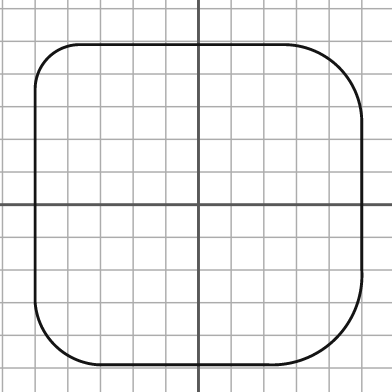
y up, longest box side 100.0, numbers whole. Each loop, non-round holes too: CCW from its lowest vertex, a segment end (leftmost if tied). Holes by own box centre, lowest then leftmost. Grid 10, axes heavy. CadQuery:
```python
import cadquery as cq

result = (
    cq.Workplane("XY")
    .moveTo(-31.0, -49.0)
    .lineTo(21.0, -49.0)
    .threePointArc((42.0, -41.0), (50.0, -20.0))
    .lineTo(50.0, 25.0)
    .threePointArc((43.0, 42.0), (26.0, 49.0))
    .lineTo(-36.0, 49.0)
    .threePointArc((-46.0, 45.0), (-50.0, 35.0))
    .lineTo(-50.0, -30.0)
    .threePointArc((-44.0, -43.0), (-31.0, -49.0))
    .close()
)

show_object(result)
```